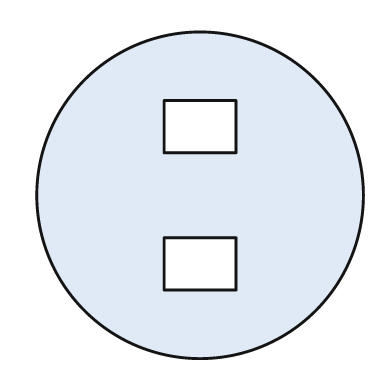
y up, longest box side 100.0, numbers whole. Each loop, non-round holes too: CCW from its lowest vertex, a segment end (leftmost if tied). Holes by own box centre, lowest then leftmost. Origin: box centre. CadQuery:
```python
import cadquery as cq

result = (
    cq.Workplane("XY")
    .moveTo(0.0, 0.0)
    .circle(50.0)
    .moveTo(-11.0, -29.0)
    .lineTo(11.0, -29.0)
    .lineTo(11.0, -13.0)
    .lineTo(-11.0, -13.0)
    .close()
    .moveTo(-11.0, 13.0)
    .lineTo(11.0, 13.0)
    .lineTo(11.0, 29.0)
    .lineTo(-11.0, 29.0)
    .close()
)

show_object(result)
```